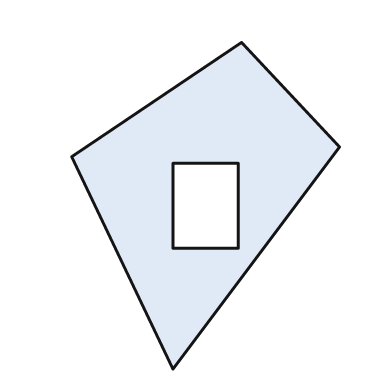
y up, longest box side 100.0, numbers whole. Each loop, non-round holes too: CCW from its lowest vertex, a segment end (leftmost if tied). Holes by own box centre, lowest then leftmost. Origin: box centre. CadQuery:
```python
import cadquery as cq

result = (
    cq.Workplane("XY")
    .moveTo(-10.0, -50.0)
    .lineTo(41.0, 18.0)
    .lineTo(11.0, 50.0)
    .lineTo(-41.0, 15.0)
    .close()
    .moveTo(-10.0, -13.0)
    .lineTo(10.0, -13.0)
    .lineTo(10.0, 13.0)
    .lineTo(-10.0, 13.0)
    .close()
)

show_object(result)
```